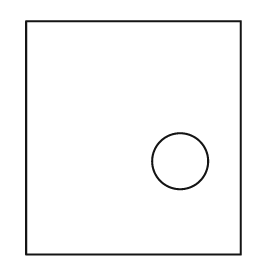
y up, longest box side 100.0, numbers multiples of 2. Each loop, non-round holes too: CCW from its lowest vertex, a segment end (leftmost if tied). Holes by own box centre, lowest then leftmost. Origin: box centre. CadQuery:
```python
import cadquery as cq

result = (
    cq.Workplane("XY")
    .moveTo(-46.0, -50.0)
    .lineTo(46.0, -50.0)
    .lineTo(46.0, 50.0)
    .lineTo(-46.0, 50.0)
    .close()
    .moveTo(20.0, -10.0)
    .circle(12.0)
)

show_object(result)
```